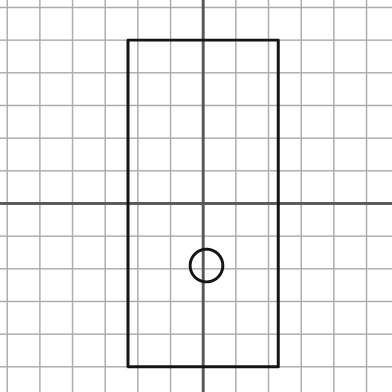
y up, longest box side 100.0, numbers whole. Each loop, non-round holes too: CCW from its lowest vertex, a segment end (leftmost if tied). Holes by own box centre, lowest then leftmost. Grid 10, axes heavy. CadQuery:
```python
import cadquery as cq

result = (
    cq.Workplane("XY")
    .moveTo(-23.0, -50.0)
    .lineTo(23.0, -50.0)
    .lineTo(23.0, 50.0)
    .lineTo(-23.0, 50.0)
    .close()
    .moveTo(1.0, -19.0)
    .circle(5.0)
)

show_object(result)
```